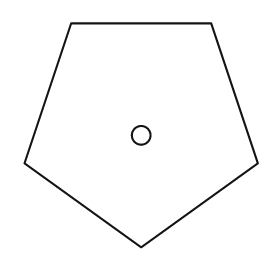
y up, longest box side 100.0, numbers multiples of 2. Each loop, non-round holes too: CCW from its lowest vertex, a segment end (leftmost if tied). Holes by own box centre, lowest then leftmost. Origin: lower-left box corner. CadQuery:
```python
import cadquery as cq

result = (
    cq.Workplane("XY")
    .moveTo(50.0, 0.0)
    .lineTo(100.0, 36.0)
    .lineTo(80.0, 96.0)
    .lineTo(20.0, 96.0)
    .lineTo(0.0, 36.0)
    .close()
    .moveTo(50.0, 48.0)
    .circle(4.0)
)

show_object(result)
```